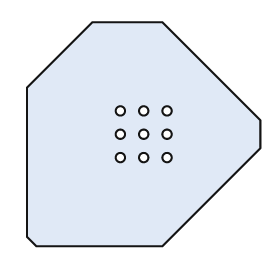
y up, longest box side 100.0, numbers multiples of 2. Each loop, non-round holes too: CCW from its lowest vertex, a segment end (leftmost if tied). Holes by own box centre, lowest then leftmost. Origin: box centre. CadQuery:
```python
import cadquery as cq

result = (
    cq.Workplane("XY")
    .moveTo(-46.0, -48.0)
    .lineTo(8.0, -48.0)
    .lineTo(50.0, -6.0)
    .lineTo(50.0, 6.0)
    .lineTo(8.0, 48.0)
    .lineTo(-22.0, 48.0)
    .lineTo(-50.0, 20.0)
    .lineTo(-50.0, -44.0)
    .close()
    .moveTo(-10.0, -10.0)
    .circle(2.0)
    .moveTo(0.0, -10.0)
    .circle(2.0)
    .moveTo(10.0, -10.0)
    .circle(2.0)
    .moveTo(-10.0, 0.0)
    .circle(2.0)
    .moveTo(0.0, 0.0)
    .circle(2.0)
    .moveTo(10.0, 0.0)
    .circle(2.0)
    .moveTo(-10.0, 10.0)
    .circle(2.0)
    .moveTo(0.0, 10.0)
    .circle(2.0)
    .moveTo(10.0, 10.0)
    .circle(2.0)
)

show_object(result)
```